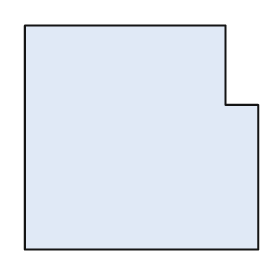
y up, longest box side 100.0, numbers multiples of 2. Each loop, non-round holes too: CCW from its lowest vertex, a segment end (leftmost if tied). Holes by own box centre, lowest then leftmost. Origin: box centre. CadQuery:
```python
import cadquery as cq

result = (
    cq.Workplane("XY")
    .moveTo(-50.0, -48.0)
    .lineTo(50.0, -48.0)
    .lineTo(50.0, 14.0)
    .lineTo(36.0, 14.0)
    .lineTo(36.0, 48.0)
    .lineTo(-50.0, 48.0)
    .close()
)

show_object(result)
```